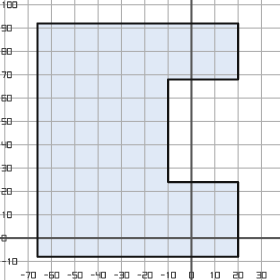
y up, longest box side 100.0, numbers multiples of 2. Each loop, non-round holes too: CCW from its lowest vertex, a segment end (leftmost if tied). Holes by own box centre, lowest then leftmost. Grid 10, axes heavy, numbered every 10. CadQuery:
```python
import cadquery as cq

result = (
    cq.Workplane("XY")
    .moveTo(-66.0, -8.0)
    .lineTo(20.0, -8.0)
    .lineTo(20.0, 24.0)
    .lineTo(-10.0, 24.0)
    .lineTo(-10.0, 68.0)
    .lineTo(20.0, 68.0)
    .lineTo(20.0, 92.0)
    .lineTo(-66.0, 92.0)
    .close()
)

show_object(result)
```